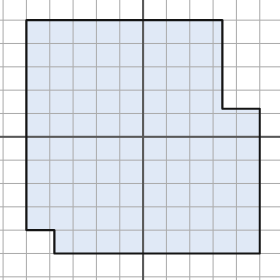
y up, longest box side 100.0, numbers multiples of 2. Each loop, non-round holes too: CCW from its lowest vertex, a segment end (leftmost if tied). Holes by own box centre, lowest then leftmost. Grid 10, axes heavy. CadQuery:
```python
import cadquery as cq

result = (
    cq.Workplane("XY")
    .moveTo(-38.0, -50.0)
    .lineTo(50.0, -50.0)
    .lineTo(50.0, 12.0)
    .lineTo(34.0, 12.0)
    .lineTo(34.0, 50.0)
    .lineTo(-50.0, 50.0)
    .lineTo(-50.0, -40.0)
    .lineTo(-38.0, -40.0)
    .close()
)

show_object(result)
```